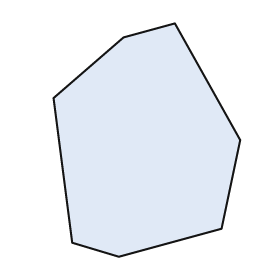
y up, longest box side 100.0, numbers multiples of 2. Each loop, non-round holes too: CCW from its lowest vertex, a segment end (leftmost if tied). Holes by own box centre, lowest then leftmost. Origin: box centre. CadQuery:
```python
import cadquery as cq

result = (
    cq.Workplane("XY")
    .moveTo(-12.0, -50.0)
    .lineTo(32.0, -38.0)
    .lineTo(40.0, 0.0)
    .lineTo(12.0, 50.0)
    .lineTo(-10.0, 44.0)
    .lineTo(-40.0, 18.0)
    .lineTo(-32.0, -44.0)
    .close()
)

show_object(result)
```